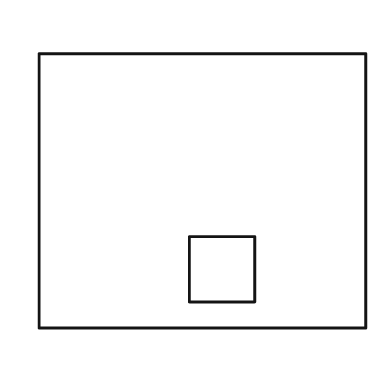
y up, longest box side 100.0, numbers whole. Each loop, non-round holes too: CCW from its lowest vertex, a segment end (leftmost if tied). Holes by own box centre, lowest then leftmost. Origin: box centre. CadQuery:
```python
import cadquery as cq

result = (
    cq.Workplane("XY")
    .moveTo(-50.0, -42.0)
    .lineTo(50.0, -42.0)
    .lineTo(50.0, 42.0)
    .lineTo(-50.0, 42.0)
    .close()
    .moveTo(-4.0, -34.0)
    .lineTo(16.0, -34.0)
    .lineTo(16.0, -14.0)
    .lineTo(-4.0, -14.0)
    .close()
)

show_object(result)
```